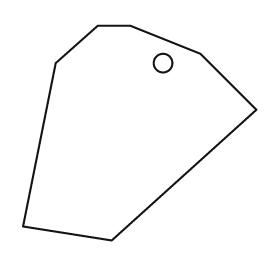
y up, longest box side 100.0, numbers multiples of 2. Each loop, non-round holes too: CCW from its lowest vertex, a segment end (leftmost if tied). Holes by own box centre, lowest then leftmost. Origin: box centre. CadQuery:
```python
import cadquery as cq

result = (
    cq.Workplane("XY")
    .moveTo(-12.0, -46.0)
    .lineTo(50.0, 10.0)
    .lineTo(26.0, 34.0)
    .lineTo(-4.0, 46.0)
    .lineTo(-18.0, 46.0)
    .lineTo(-36.0, 30.0)
    .lineTo(-50.0, -40.0)
    .close()
    .moveTo(10.0, 30.0)
    .circle(4.0)
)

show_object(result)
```